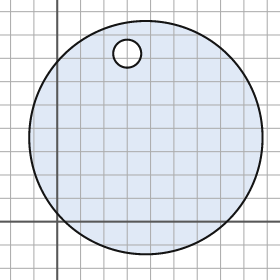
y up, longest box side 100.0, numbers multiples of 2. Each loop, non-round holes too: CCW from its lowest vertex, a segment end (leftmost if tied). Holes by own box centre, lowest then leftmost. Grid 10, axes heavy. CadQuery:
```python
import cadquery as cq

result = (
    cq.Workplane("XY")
    .moveTo(38.0, 36.0)
    .circle(50.0)
    .moveTo(30.0, 72.0)
    .circle(6.0)
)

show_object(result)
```